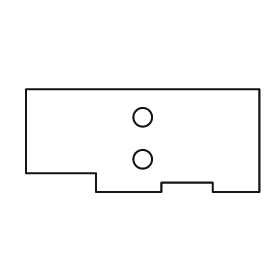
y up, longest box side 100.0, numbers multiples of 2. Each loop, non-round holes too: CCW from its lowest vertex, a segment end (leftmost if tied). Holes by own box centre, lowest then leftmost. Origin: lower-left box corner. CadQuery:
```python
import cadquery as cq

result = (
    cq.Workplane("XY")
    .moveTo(30.0, 0.0)
    .lineTo(58.0, 0.0)
    .lineTo(58.0, 4.0)
    .lineTo(80.0, 4.0)
    .lineTo(80.0, 0.0)
    .lineTo(100.0, 0.0)
    .lineTo(100.0, 44.0)
    .lineTo(0.0, 44.0)
    .lineTo(0.0, 8.0)
    .lineTo(30.0, 8.0)
    .close()
    .moveTo(50.0, 14.0)
    .circle(4.0)
    .moveTo(50.0, 32.0)
    .circle(4.0)
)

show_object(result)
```